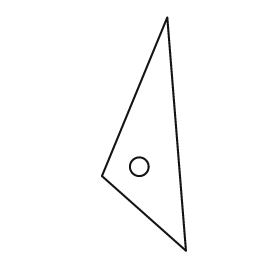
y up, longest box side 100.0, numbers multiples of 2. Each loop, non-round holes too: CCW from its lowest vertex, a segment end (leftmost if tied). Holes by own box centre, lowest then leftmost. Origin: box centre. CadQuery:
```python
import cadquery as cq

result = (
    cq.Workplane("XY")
    .moveTo(18.0, -50.0)
    .lineTo(10.0, 50.0)
    .lineTo(-18.0, -18.0)
    .close()
    .moveTo(-2.0, -14.0)
    .circle(4.0)
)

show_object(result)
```